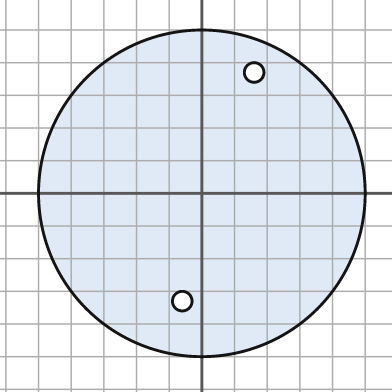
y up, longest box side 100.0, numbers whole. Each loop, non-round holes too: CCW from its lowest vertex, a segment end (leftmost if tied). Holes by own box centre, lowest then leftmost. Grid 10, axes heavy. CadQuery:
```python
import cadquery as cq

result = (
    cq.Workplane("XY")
    .moveTo(0.0, 0.0)
    .circle(50.0)
    .moveTo(-6.0, -33.0)
    .circle(3.0)
    .moveTo(16.0, 37.0)
    .circle(3.0)
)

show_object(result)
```